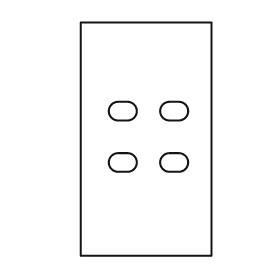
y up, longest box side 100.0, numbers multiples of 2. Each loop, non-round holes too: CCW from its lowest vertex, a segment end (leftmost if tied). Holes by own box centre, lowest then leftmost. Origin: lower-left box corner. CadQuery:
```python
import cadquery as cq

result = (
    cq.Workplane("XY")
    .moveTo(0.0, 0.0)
    .lineTo(56.0, 0.0)
    .lineTo(56.0, 100.0)
    .lineTo(0.0, 100.0)
    .close()
    .moveTo(16.0, 36.0)
    .lineTo(20.0, 36.0)
    .threePointArc((24.0, 40.0), (20.0, 44.0))
    .lineTo(16.0, 44.0)
    .threePointArc((12.0, 40.0), (16.0, 36.0))
    .close()
    .moveTo(38.0, 36.0)
    .lineTo(42.0, 36.0)
    .threePointArc((46.0, 40.0), (42.0, 44.0))
    .lineTo(38.0, 44.0)
    .threePointArc((34.0, 40.0), (38.0, 36.0))
    .close()
    .moveTo(16.0, 58.0)
    .lineTo(20.0, 58.0)
    .threePointArc((24.0, 62.0), (20.0, 66.0))
    .lineTo(16.0, 66.0)
    .threePointArc((12.0, 62.0), (16.0, 58.0))
    .close()
    .moveTo(38.0, 58.0)
    .lineTo(42.0, 58.0)
    .threePointArc((46.0, 62.0), (42.0, 66.0))
    .lineTo(38.0, 66.0)
    .threePointArc((34.0, 62.0), (38.0, 58.0))
    .close()
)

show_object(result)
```